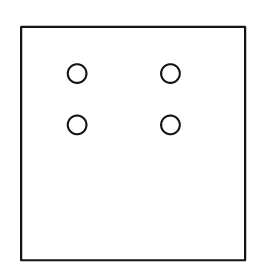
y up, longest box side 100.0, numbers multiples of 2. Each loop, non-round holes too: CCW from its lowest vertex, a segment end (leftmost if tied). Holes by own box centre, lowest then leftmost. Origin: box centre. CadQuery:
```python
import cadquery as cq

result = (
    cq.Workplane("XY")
    .moveTo(-48.0, -50.0)
    .lineTo(48.0, -50.0)
    .lineTo(48.0, 50.0)
    .lineTo(-48.0, 50.0)
    .close()
    .moveTo(-24.0, 8.0)
    .circle(4.0)
    .moveTo(16.0, 8.0)
    .circle(4.0)
    .moveTo(-24.0, 30.0)
    .circle(4.0)
    .moveTo(16.0, 30.0)
    .circle(4.0)
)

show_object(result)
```